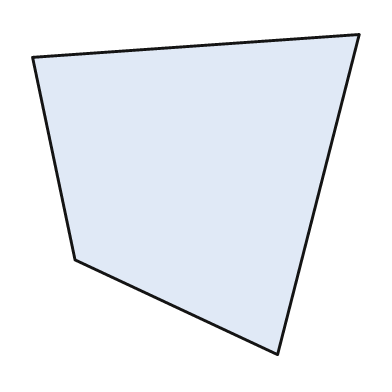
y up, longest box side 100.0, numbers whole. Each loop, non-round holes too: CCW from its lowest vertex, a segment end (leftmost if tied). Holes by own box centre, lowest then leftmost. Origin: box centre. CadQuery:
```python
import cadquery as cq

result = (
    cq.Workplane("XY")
    .moveTo(25.0, -49.0)
    .lineTo(50.0, 49.0)
    .lineTo(-50.0, 42.0)
    .lineTo(-37.0, -20.0)
    .close()
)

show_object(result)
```